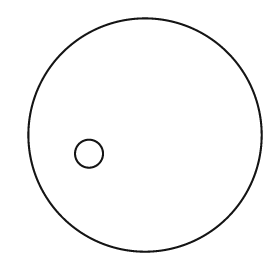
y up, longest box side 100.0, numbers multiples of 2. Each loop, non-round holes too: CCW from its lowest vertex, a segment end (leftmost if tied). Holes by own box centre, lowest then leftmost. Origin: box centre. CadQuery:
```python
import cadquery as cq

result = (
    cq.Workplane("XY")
    .moveTo(0.0, 0.0)
    .circle(50.0)
    .moveTo(-24.0, -8.0)
    .circle(6.0)
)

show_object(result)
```